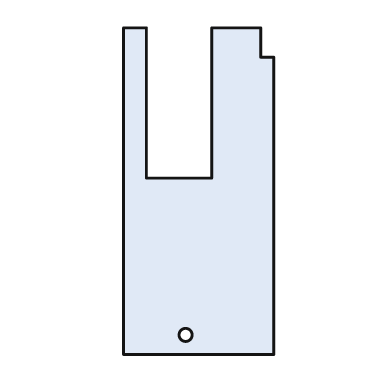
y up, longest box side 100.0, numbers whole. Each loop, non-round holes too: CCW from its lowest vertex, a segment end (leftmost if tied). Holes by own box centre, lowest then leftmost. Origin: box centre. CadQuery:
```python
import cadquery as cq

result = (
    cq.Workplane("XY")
    .moveTo(-23.0, -50.0)
    .lineTo(23.0, -50.0)
    .lineTo(23.0, 41.0)
    .lineTo(19.0, 41.0)
    .lineTo(19.0, 50.0)
    .lineTo(4.0, 50.0)
    .lineTo(4.0, 4.0)
    .lineTo(-16.0, 4.0)
    .lineTo(-16.0, 50.0)
    .lineTo(-23.0, 50.0)
    .close()
    .moveTo(-4.0, -44.0)
    .circle(2.0)
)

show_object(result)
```